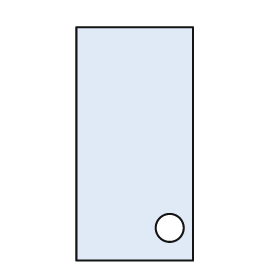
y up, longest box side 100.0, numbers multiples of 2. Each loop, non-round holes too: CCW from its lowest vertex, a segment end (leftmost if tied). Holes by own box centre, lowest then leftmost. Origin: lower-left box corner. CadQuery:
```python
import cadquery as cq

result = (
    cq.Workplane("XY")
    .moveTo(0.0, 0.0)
    .lineTo(50.0, 0.0)
    .lineTo(50.0, 100.0)
    .lineTo(0.0, 100.0)
    .close()
    .moveTo(40.0, 14.0)
    .circle(6.0)
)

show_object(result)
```